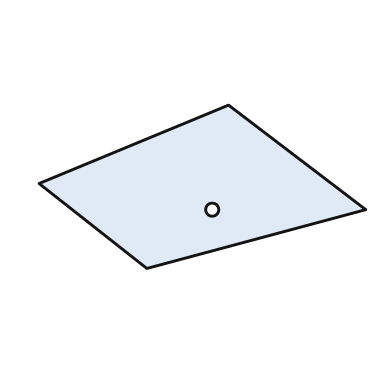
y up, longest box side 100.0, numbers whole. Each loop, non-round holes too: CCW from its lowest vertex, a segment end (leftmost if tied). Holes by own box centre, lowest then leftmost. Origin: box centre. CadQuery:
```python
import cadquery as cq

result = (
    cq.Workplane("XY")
    .moveTo(-17.0, -25.0)
    .lineTo(50.0, -7.0)
    .lineTo(8.0, 25.0)
    .lineTo(-50.0, 1.0)
    .close()
    .moveTo(3.0, -7.0)
    .circle(2.0)
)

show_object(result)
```